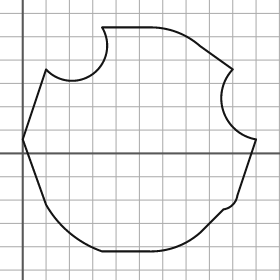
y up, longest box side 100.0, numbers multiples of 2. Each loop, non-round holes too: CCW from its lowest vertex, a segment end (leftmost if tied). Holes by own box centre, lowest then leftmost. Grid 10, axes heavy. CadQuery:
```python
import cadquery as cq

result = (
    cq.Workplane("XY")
    .moveTo(34.0, -42.0)
    .lineTo(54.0, -42.0)
    .threePointArc((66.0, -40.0), (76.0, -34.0))
    .lineTo(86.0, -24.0)
    .threePointArc((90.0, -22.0), (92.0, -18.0))
    .lineTo(100.0, 6.0)
    .threePointArc((86.0, 18.0), (90.0, 36.0))
    .lineTo(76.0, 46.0)
    .threePointArc((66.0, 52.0), (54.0, 54.0))
    .lineTo(34.0, 54.0)
    .threePointArc((30.0, 34.0), (10.0, 36.0))
    .lineTo(0.0, 6.0)
    .lineTo(10.0, -22.0)
    .threePointArc((20.0, -34.0), (34.0, -42.0))
    .close()
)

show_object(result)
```